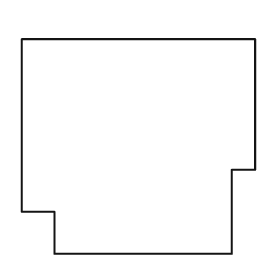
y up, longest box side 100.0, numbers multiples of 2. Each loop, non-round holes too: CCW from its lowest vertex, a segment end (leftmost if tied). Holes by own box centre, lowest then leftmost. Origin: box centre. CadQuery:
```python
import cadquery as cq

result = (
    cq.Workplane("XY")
    .moveTo(-36.0, -46.0)
    .lineTo(40.0, -46.0)
    .lineTo(40.0, -10.0)
    .lineTo(50.0, -10.0)
    .lineTo(50.0, 46.0)
    .lineTo(-50.0, 46.0)
    .lineTo(-50.0, -28.0)
    .lineTo(-36.0, -28.0)
    .close()
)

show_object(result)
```